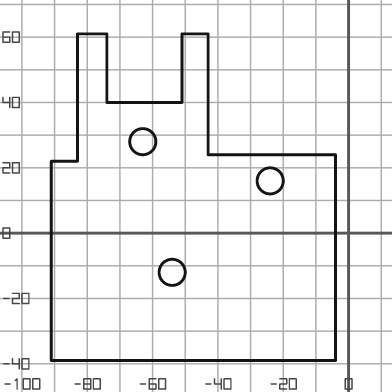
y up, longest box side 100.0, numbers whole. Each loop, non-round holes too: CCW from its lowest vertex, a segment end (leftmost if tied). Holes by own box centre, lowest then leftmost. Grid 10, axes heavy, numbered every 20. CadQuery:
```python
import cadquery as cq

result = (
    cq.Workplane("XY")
    .moveTo(-91.0, -39.0)
    .lineTo(-4.0, -39.0)
    .lineTo(-4.0, 24.0)
    .lineTo(-43.0, 24.0)
    .lineTo(-43.0, 61.0)
    .lineTo(-51.0, 61.0)
    .lineTo(-51.0, 40.0)
    .lineTo(-74.0, 40.0)
    .lineTo(-74.0, 61.0)
    .lineTo(-83.0, 61.0)
    .lineTo(-83.0, 22.0)
    .lineTo(-91.0, 22.0)
    .close()
    .moveTo(-54.0, -12.0)
    .circle(4.0)
    .moveTo(-24.0, 16.0)
    .circle(4.0)
    .moveTo(-63.0, 28.0)
    .circle(4.0)
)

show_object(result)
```